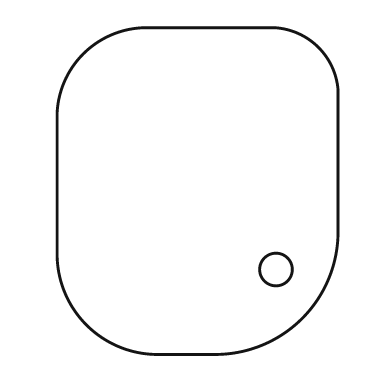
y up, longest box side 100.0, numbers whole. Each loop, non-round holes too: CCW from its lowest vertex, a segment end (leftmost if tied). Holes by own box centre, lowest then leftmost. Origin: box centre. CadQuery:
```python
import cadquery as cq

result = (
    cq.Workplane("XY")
    .moveTo(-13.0, -50.0)
    .lineTo(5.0, -50.0)
    .threePointArc((32.0, -39.0), (43.0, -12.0))
    .lineTo(43.0, 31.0)
    .threePointArc((37.0, 44.0), (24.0, 50.0))
    .lineTo(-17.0, 50.0)
    .threePointArc((-35.0, 42.0), (-43.0, 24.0))
    .lineTo(-43.0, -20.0)
    .threePointArc((-34.0, -41.0), (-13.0, -50.0))
    .close()
    .moveTo(24.0, -24.0)
    .circle(5.0)
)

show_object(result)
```